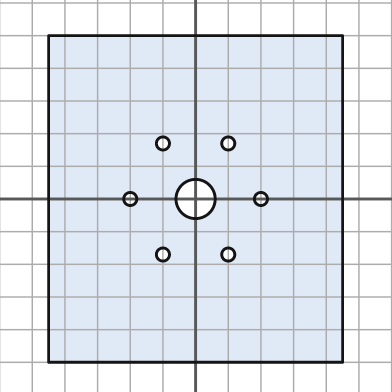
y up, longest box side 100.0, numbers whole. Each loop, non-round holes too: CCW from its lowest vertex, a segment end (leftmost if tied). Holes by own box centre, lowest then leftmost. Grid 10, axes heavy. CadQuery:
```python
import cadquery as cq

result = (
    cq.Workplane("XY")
    .moveTo(-45.0, -50.0)
    .lineTo(45.0, -50.0)
    .lineTo(45.0, 50.0)
    .lineTo(-45.0, 50.0)
    .close()
    .moveTo(-10.0, -17.0)
    .circle(2.0)
    .moveTo(10.0, -17.0)
    .circle(2.0)
    .moveTo(-20.0, 0.0)
    .circle(2.0)
    .moveTo(0.0, 0.0)
    .circle(6.0)
    .moveTo(20.0, 0.0)
    .circle(2.0)
    .moveTo(-10.0, 17.0)
    .circle(2.0)
    .moveTo(10.0, 17.0)
    .circle(2.0)
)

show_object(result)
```